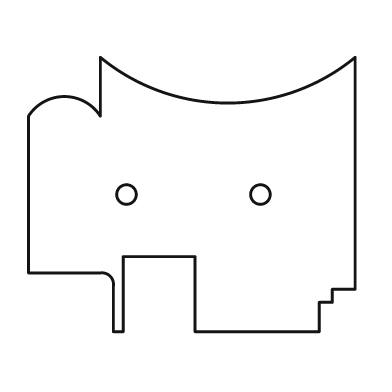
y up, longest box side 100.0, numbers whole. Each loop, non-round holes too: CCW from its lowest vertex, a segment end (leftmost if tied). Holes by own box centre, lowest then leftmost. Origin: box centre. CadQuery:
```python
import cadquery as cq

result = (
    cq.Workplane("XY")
    .moveTo(-24.0, -42.0)
    .lineTo(-21.0, -42.0)
    .lineTo(-21.0, -19.0)
    .lineTo(1.0, -19.0)
    .lineTo(1.0, -42.0)
    .lineTo(39.0, -42.0)
    .lineTo(39.0, -33.0)
    .lineTo(43.0, -33.0)
    .lineTo(43.0, -29.0)
    .lineTo(50.0, -29.0)
    .lineTo(50.0, 42.0)
    .threePointArc((11.0, 28.0), (-28.0, 42.0))
    .lineTo(-28.0, 24.0)
    .threePointArc((-39.0, 30.0), (-50.0, 24.0))
    .lineTo(-50.0, -24.0)
    .lineTo(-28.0, -24.0)
    .threePointArc((-25.0, -25.0), (-24.0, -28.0))
    .close()
    .moveTo(-20.0, 0.0)
    .circle(3.0)
    .moveTo(21.0, 0.0)
    .circle(3.0)
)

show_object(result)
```